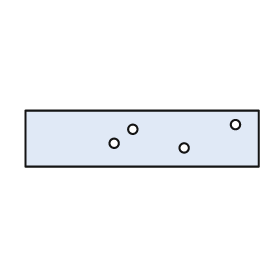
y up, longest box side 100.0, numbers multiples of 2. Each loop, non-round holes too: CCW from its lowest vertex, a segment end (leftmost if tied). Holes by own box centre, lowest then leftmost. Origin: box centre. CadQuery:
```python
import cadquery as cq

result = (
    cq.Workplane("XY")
    .moveTo(-50.0, -12.0)
    .lineTo(50.0, -12.0)
    .lineTo(50.0, 12.0)
    .lineTo(-50.0, 12.0)
    .close()
    .moveTo(18.0, -4.0)
    .circle(2.0)
    .moveTo(-12.0, -2.0)
    .circle(2.0)
    .moveTo(-4.0, 4.0)
    .circle(2.0)
    .moveTo(40.0, 6.0)
    .circle(2.0)
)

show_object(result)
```